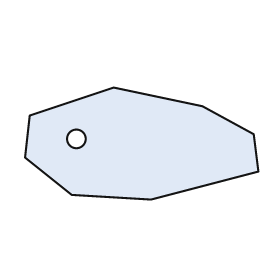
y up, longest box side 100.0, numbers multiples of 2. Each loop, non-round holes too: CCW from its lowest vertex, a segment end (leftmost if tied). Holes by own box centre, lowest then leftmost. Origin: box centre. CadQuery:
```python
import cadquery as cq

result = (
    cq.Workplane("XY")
    .moveTo(4.0, -24.0)
    .lineTo(50.0, -12.0)
    .lineTo(48.0, 4.0)
    .lineTo(26.0, 16.0)
    .lineTo(-12.0, 24.0)
    .lineTo(-48.0, 12.0)
    .lineTo(-50.0, -6.0)
    .lineTo(-30.0, -22.0)
    .close()
    .moveTo(-28.0, 2.0)
    .circle(4.0)
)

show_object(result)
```